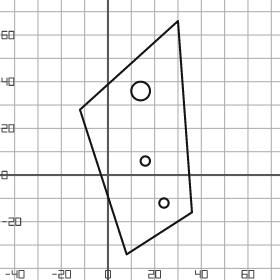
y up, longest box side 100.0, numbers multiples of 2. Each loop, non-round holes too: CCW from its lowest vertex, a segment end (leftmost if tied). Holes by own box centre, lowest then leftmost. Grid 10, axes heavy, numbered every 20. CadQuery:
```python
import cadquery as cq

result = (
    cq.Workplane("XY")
    .moveTo(8.0, -34.0)
    .lineTo(36.0, -16.0)
    .lineTo(30.0, 66.0)
    .lineTo(-12.0, 28.0)
    .close()
    .moveTo(24.0, -12.0)
    .circle(2.0)
    .moveTo(16.0, 6.0)
    .circle(2.0)
    .moveTo(14.0, 36.0)
    .circle(4.0)
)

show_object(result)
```